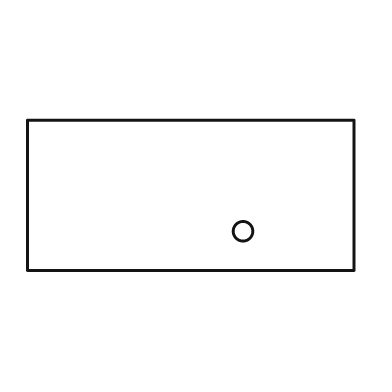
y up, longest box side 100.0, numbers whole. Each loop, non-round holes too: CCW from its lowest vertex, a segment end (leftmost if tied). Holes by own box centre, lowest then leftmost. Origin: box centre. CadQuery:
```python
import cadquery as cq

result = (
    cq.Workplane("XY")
    .moveTo(-50.0, -23.0)
    .lineTo(50.0, -23.0)
    .lineTo(50.0, 23.0)
    .lineTo(-50.0, 23.0)
    .close()
    .moveTo(16.0, -11.0)
    .circle(3.0)
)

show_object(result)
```